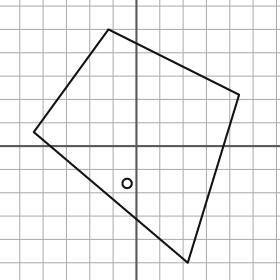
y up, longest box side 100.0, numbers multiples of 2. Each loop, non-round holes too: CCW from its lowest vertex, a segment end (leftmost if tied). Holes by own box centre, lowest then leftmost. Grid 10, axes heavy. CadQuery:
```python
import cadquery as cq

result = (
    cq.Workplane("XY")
    .moveTo(22.0, -50.0)
    .lineTo(44.0, 22.0)
    .lineTo(-12.0, 50.0)
    .lineTo(-44.0, 6.0)
    .close()
    .moveTo(-4.0, -16.0)
    .circle(2.0)
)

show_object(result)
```